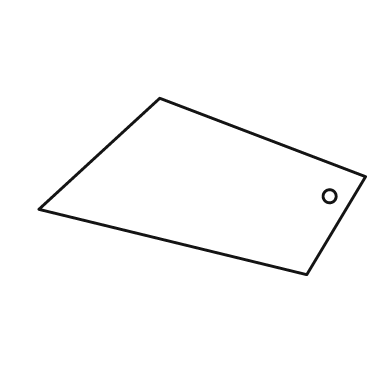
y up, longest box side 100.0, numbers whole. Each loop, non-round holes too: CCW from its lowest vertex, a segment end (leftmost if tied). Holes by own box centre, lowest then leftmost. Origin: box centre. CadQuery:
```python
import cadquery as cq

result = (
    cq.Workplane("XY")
    .moveTo(32.0, -27.0)
    .lineTo(50.0, 3.0)
    .lineTo(-13.0, 27.0)
    .lineTo(-50.0, -7.0)
    .close()
    .moveTo(39.0, -3.0)
    .circle(2.0)
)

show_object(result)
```